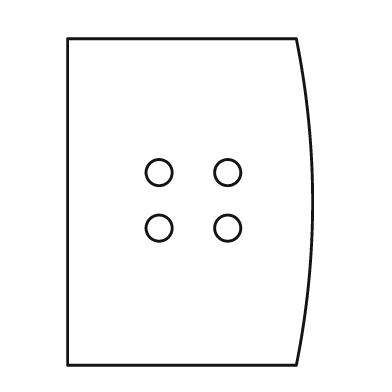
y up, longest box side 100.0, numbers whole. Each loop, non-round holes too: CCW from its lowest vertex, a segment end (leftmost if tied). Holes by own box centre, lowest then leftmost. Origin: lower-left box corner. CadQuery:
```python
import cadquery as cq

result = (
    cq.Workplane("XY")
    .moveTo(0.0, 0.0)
    .lineTo(70.0, 0.0)
    .threePointArc((75.0, 50.0), (70.0, 100.0))
    .lineTo(0.0, 100.0)
    .close()
    .moveTo(28.0, 42.0)
    .circle(4.0)
    .moveTo(49.0, 42.0)
    .circle(4.0)
    .moveTo(28.0, 59.0)
    .circle(4.0)
    .moveTo(49.0, 59.0)
    .circle(4.0)
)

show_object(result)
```